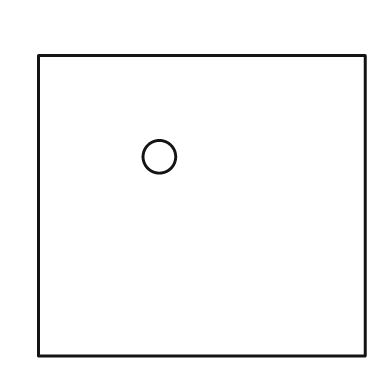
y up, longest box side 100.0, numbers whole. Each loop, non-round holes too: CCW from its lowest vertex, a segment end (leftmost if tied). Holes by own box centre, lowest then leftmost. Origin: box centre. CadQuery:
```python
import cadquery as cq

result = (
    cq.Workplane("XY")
    .moveTo(-50.0, -46.0)
    .lineTo(50.0, -46.0)
    .lineTo(50.0, 46.0)
    .lineTo(-50.0, 46.0)
    .close()
    .moveTo(-13.0, 15.0)
    .circle(5.0)
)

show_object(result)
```